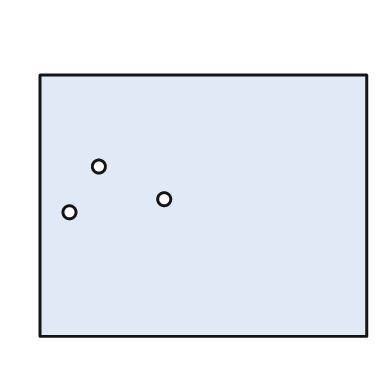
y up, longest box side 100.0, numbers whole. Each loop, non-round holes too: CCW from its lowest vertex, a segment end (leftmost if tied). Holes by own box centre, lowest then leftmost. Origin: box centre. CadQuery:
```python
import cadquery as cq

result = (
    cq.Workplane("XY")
    .moveTo(-50.0, -40.0)
    .lineTo(50.0, -40.0)
    .lineTo(50.0, 40.0)
    .lineTo(-50.0, 40.0)
    .close()
    .moveTo(-41.0, -2.0)
    .circle(2.0)
    .moveTo(-12.0, 2.0)
    .circle(2.0)
    .moveTo(-32.0, 12.0)
    .circle(2.0)
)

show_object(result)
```